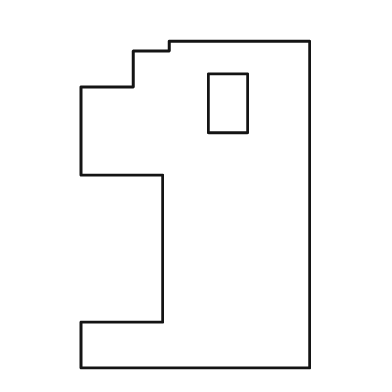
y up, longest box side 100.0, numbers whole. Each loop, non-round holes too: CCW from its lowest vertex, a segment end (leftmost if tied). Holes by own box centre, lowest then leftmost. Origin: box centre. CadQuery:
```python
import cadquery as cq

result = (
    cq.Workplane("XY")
    .moveTo(-35.0, -50.0)
    .lineTo(35.0, -50.0)
    .lineTo(35.0, 50.0)
    .lineTo(-8.0, 50.0)
    .lineTo(-8.0, 47.0)
    .lineTo(-19.0, 47.0)
    .lineTo(-19.0, 36.0)
    .lineTo(-35.0, 36.0)
    .lineTo(-35.0, 9.0)
    .lineTo(-10.0, 9.0)
    .lineTo(-10.0, -36.0)
    .lineTo(-35.0, -36.0)
    .close()
    .moveTo(4.0, 22.0)
    .lineTo(16.0, 22.0)
    .lineTo(16.0, 40.0)
    .lineTo(4.0, 40.0)
    .close()
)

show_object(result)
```